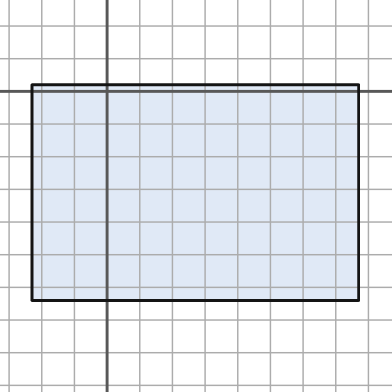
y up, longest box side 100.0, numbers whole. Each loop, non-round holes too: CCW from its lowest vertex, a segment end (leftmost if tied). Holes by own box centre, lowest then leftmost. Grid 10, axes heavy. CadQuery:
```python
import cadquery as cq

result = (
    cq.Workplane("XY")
    .moveTo(-23.0, -64.0)
    .lineTo(77.0, -64.0)
    .lineTo(77.0, 2.0)
    .lineTo(-23.0, 2.0)
    .close()
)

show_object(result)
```